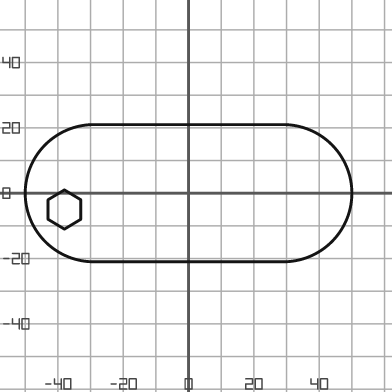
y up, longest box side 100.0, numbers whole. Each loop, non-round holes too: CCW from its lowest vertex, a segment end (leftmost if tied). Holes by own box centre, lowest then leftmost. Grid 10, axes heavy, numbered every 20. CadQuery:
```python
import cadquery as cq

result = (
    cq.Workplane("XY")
    .moveTo(-29.0, -21.0)
    .lineTo(29.0, -21.0)
    .threePointArc((50.0, 0.0), (29.0, 21.0))
    .lineTo(-29.0, 21.0)
    .threePointArc((-50.0, 0.0), (-29.0, -21.0))
    .close()
    .moveTo(-38.0, -11.0)
    .lineTo(-33.0, -8.0)
    .lineTo(-33.0, -2.0)
    .lineTo(-38.0, 1.0)
    .lineTo(-43.0, -2.0)
    .lineTo(-43.0, -8.0)
    .close()
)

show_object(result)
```